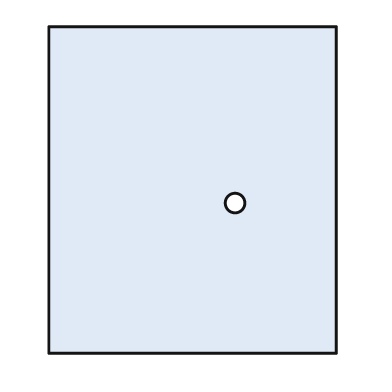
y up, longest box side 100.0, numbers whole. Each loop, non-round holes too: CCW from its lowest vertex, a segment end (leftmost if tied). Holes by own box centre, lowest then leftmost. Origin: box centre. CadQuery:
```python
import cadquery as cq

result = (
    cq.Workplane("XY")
    .moveTo(-44.0, -50.0)
    .lineTo(44.0, -50.0)
    .lineTo(44.0, 50.0)
    .lineTo(-44.0, 50.0)
    .close()
    .moveTo(13.0, -4.0)
    .circle(3.0)
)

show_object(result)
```